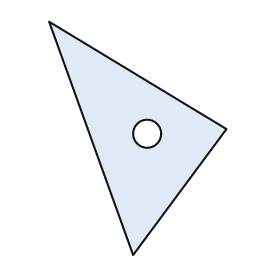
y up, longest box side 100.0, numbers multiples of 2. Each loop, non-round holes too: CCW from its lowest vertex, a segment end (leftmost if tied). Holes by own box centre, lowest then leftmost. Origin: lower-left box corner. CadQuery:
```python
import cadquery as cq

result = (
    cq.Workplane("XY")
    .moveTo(36.0, 0.0)
    .lineTo(76.0, 54.0)
    .lineTo(0.0, 100.0)
    .close()
    .moveTo(42.0, 52.0)
    .circle(6.0)
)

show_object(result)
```